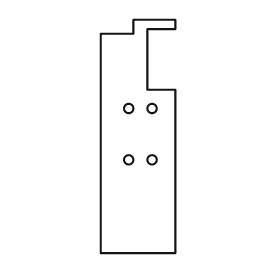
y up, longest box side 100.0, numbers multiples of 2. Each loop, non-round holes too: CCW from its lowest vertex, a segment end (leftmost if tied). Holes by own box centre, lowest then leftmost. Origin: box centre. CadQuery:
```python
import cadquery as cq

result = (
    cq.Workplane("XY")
    .moveTo(-16.0, -50.0)
    .lineTo(16.0, -50.0)
    .lineTo(16.0, 20.0)
    .lineTo(4.0, 20.0)
    .lineTo(4.0, 46.0)
    .lineTo(16.0, 46.0)
    .lineTo(16.0, 50.0)
    .lineTo(-2.0, 50.0)
    .lineTo(-2.0, 44.0)
    .lineTo(-16.0, 44.0)
    .close()
    .moveTo(-4.0, -10.0)
    .circle(2.0)
    .moveTo(6.0, -10.0)
    .circle(2.0)
    .moveTo(-4.0, 12.0)
    .circle(2.0)
    .moveTo(6.0, 12.0)
    .circle(2.0)
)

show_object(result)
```